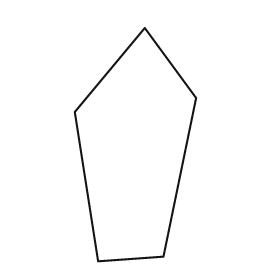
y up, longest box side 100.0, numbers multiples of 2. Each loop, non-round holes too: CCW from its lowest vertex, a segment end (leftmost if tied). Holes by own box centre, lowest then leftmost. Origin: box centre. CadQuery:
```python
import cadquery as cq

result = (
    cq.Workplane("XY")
    .moveTo(-16.0, -50.0)
    .lineTo(12.0, -48.0)
    .lineTo(26.0, 20.0)
    .lineTo(4.0, 50.0)
    .lineTo(-26.0, 14.0)
    .close()
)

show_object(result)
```